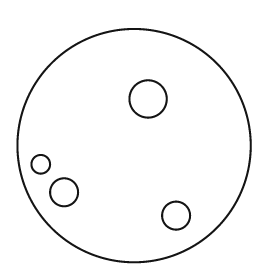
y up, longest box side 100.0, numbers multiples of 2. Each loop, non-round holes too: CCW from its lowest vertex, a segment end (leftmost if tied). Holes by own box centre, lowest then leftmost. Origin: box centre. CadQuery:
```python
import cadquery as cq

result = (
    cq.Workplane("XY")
    .moveTo(0.0, 0.0)
    .circle(50.0)
    .moveTo(18.0, -30.0)
    .circle(6.0)
    .moveTo(-30.0, -20.0)
    .circle(6.0)
    .moveTo(-40.0, -8.0)
    .circle(4.0)
    .moveTo(6.0, 20.0)
    .circle(8.0)
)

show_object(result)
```